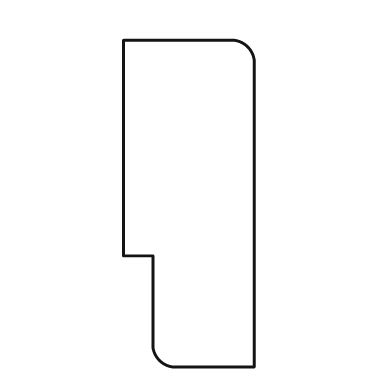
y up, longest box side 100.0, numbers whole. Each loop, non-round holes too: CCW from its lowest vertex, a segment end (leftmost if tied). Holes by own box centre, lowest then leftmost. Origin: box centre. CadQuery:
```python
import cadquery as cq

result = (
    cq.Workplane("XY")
    .moveTo(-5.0, -50.0)
    .lineTo(20.0, -50.0)
    .lineTo(20.0, 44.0)
    .threePointArc((18.0, 48.0), (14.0, 50.0))
    .lineTo(-20.0, 50.0)
    .lineTo(-20.0, -16.0)
    .lineTo(-11.0, -16.0)
    .lineTo(-11.0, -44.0)
    .threePointArc((-9.0, -48.0), (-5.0, -50.0))
    .close()
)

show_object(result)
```